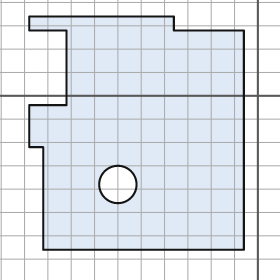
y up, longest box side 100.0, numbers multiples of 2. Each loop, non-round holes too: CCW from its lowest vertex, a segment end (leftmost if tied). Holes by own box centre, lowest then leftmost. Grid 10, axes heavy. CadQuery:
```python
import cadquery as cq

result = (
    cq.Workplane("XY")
    .moveTo(-92.0, -66.0)
    .lineTo(-6.0, -66.0)
    .lineTo(-6.0, 28.0)
    .lineTo(-36.0, 28.0)
    .lineTo(-36.0, 34.0)
    .lineTo(-98.0, 34.0)
    .lineTo(-98.0, 28.0)
    .lineTo(-82.0, 28.0)
    .lineTo(-82.0, -4.0)
    .lineTo(-98.0, -4.0)
    .lineTo(-98.0, -22.0)
    .lineTo(-92.0, -22.0)
    .close()
    .moveTo(-60.0, -38.0)
    .circle(8.0)
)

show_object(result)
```